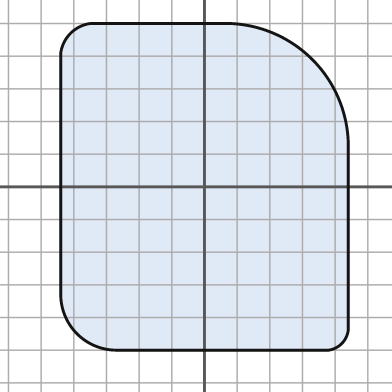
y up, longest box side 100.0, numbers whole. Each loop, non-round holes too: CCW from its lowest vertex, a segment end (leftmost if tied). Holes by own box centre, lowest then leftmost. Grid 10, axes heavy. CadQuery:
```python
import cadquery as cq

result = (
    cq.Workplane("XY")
    .moveTo(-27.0, -50.0)
    .lineTo(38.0, -50.0)
    .threePointArc((42.0, -48.0), (44.0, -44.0))
    .lineTo(44.0, 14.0)
    .threePointArc((33.0, 39.0), (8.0, 50.0))
    .lineTo(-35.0, 50.0)
    .threePointArc((-41.0, 47.0), (-44.0, 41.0))
    .lineTo(-44.0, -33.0)
    .threePointArc((-39.0, -45.0), (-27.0, -50.0))
    .close()
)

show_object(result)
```